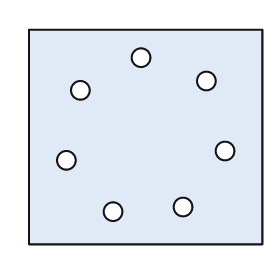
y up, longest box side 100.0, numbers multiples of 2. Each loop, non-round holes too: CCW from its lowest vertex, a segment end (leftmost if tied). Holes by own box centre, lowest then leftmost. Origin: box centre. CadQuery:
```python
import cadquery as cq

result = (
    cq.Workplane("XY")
    .moveTo(-50.0, -46.0)
    .lineTo(50.0, -46.0)
    .lineTo(50.0, 46.0)
    .lineTo(-50.0, 46.0)
    .close()
    .moveTo(-14.0, -32.0)
    .circle(4.0)
    .moveTo(16.0, -30.0)
    .circle(4.0)
    .moveTo(-34.0, -10.0)
    .circle(4.0)
    .moveTo(34.0, -6.0)
    .circle(4.0)
    .moveTo(-28.0, 20.0)
    .circle(4.0)
    .moveTo(26.0, 24.0)
    .circle(4.0)
    .moveTo(-2.0, 34.0)
    .circle(4.0)
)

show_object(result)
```